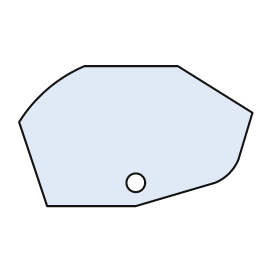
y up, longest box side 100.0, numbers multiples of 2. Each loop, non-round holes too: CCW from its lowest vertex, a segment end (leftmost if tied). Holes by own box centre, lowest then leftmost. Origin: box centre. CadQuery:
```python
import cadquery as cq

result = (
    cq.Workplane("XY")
    .moveTo(-38.0, -30.0)
    .lineTo(0.0, -30.0)
    .lineTo(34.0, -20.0)
    .threePointArc((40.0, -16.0), (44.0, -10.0))
    .lineTo(50.0, 10.0)
    .lineTo(18.0, 30.0)
    .lineTo(-22.0, 30.0)
    .threePointArc((-38.0, 20.0), (-50.0, 6.0))
    .close()
    .moveTo(0.0, -20.0)
    .circle(4.0)
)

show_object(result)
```